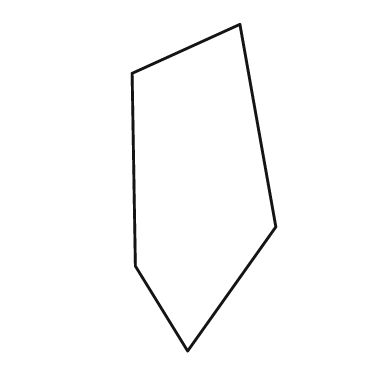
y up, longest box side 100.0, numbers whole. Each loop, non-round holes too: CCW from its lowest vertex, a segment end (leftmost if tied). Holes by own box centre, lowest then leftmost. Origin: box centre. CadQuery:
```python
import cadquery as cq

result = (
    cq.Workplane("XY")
    .moveTo(-5.0, -50.0)
    .lineTo(22.0, -12.0)
    .lineTo(11.0, 50.0)
    .lineTo(-22.0, 35.0)
    .lineTo(-21.0, -24.0)
    .close()
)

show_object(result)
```